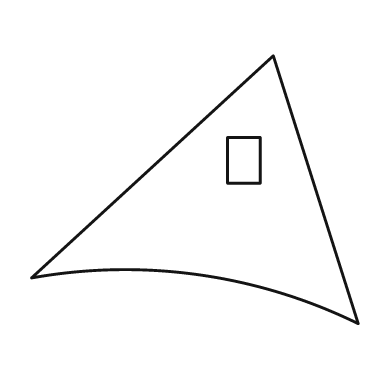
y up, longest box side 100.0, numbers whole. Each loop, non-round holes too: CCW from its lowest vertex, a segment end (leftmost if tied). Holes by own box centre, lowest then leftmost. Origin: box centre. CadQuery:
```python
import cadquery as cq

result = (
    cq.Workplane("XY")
    .moveTo(50.0, -41.0)
    .lineTo(24.0, 41.0)
    .lineTo(-50.0, -27.0)
    .threePointArc((1.0, -26.0), (50.0, -41.0))
    .close()
    .moveTo(10.0, 2.0)
    .lineTo(20.0, 2.0)
    .lineTo(20.0, 16.0)
    .lineTo(10.0, 16.0)
    .close()
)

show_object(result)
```